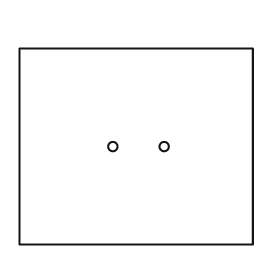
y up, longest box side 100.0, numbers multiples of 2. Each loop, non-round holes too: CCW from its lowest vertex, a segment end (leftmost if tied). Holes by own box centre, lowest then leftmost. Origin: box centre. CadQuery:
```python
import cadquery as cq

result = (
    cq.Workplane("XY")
    .moveTo(-50.0, -42.0)
    .lineTo(50.0, -42.0)
    .lineTo(50.0, 42.0)
    .lineTo(-50.0, 42.0)
    .close()
    .moveTo(-10.0, 0.0)
    .circle(2.0)
    .moveTo(12.0, 0.0)
    .circle(2.0)
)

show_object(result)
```